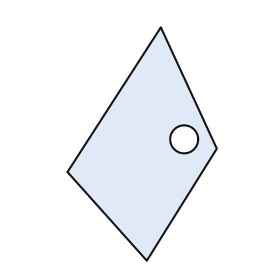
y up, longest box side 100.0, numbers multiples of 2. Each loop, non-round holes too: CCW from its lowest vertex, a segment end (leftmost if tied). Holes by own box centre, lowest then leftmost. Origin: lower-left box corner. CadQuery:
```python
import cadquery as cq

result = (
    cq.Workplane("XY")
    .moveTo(34.0, 0.0)
    .lineTo(64.0, 48.0)
    .lineTo(40.0, 100.0)
    .lineTo(0.0, 38.0)
    .close()
    .moveTo(50.0, 52.0)
    .circle(6.0)
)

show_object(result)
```